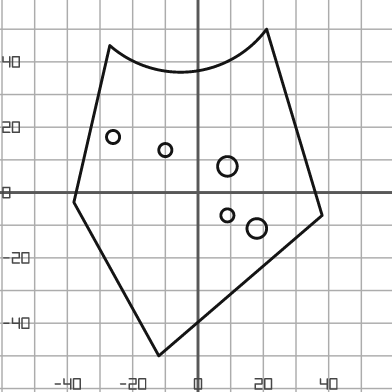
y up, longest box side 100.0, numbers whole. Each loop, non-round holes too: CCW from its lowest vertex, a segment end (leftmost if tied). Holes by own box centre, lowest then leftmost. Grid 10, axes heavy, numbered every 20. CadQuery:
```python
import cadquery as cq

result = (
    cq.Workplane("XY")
    .moveTo(-12.0, -50.0)
    .lineTo(38.0, -7.0)
    .lineTo(21.0, 50.0)
    .threePointArc((-2.0, 37.0), (-27.0, 45.0))
    .lineTo(-38.0, -3.0)
    .close()
    .moveTo(18.0, -11.0)
    .circle(3.0)
    .moveTo(9.0, -7.0)
    .circle(2.0)
    .moveTo(9.0, 8.0)
    .circle(3.0)
    .moveTo(-10.0, 13.0)
    .circle(2.0)
    .moveTo(-26.0, 17.0)
    .circle(2.0)
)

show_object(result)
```